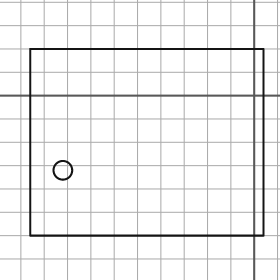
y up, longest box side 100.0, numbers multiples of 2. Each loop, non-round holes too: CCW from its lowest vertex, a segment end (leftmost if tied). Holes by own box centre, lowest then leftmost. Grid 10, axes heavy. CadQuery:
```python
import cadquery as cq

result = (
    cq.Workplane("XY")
    .moveTo(-96.0, -60.0)
    .lineTo(4.0, -60.0)
    .lineTo(4.0, 20.0)
    .lineTo(-96.0, 20.0)
    .close()
    .moveTo(-82.0, -32.0)
    .circle(4.0)
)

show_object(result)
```